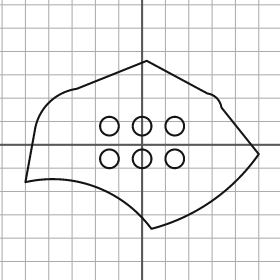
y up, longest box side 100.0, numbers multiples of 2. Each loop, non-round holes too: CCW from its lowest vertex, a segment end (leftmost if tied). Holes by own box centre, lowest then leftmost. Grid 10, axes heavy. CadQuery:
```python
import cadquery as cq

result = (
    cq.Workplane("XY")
    .moveTo(4.0, -36.0)
    .threePointArc((30.0, -24.0), (50.0, -4.0))
    .lineTo(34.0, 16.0)
    .threePointArc((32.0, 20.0), (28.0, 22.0))
    .lineTo(2.0, 36.0)
    .lineTo(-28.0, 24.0)
    .threePointArc((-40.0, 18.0), (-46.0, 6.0))
    .lineTo(-50.0, -16.0)
    .threePointArc((-20.0, -18.0), (4.0, -36.0))
    .close()
    .moveTo(-14.0, -6.0)
    .circle(4.0)
    .moveTo(0.0, -6.0)
    .circle(4.0)
    .moveTo(14.0, -6.0)
    .circle(4.0)
    .moveTo(-14.0, 8.0)
    .circle(4.0)
    .moveTo(0.0, 8.0)
    .circle(4.0)
    .moveTo(14.0, 8.0)
    .circle(4.0)
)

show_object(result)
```